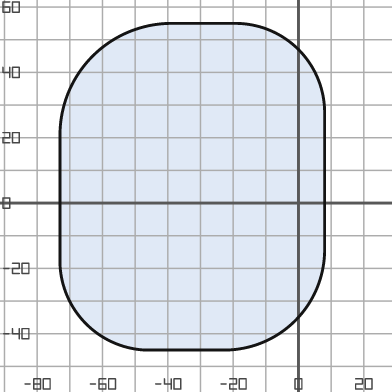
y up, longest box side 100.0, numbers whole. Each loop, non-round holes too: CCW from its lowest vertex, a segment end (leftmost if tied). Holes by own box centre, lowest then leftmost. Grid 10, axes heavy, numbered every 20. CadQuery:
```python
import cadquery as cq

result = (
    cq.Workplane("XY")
    .moveTo(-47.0, -45.0)
    .lineTo(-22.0, -45.0)
    .threePointArc((-1.0, -36.0), (8.0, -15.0))
    .lineTo(8.0, 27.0)
    .threePointArc((0.0, 47.0), (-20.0, 55.0))
    .lineTo(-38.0, 55.0)
    .threePointArc((-63.0, 45.0), (-73.0, 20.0))
    .lineTo(-73.0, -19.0)
    .threePointArc((-65.0, -37.0), (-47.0, -45.0))
    .close()
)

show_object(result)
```